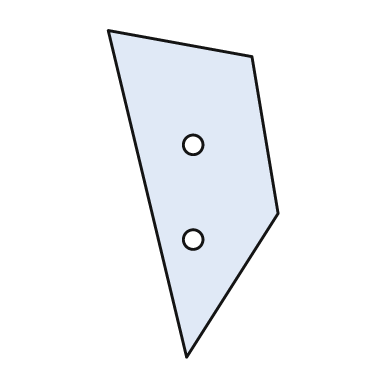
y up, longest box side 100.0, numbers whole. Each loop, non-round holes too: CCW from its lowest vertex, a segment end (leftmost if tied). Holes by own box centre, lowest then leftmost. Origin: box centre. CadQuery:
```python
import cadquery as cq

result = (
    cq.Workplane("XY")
    .moveTo(-2.0, -50.0)
    .lineTo(26.0, -6.0)
    .lineTo(18.0, 42.0)
    .lineTo(-26.0, 50.0)
    .close()
    .moveTo(0.0, -14.0)
    .circle(3.0)
    .moveTo(0.0, 15.0)
    .circle(3.0)
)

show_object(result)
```